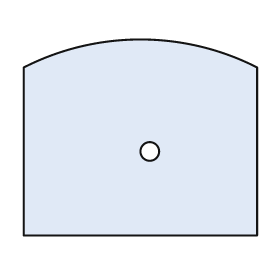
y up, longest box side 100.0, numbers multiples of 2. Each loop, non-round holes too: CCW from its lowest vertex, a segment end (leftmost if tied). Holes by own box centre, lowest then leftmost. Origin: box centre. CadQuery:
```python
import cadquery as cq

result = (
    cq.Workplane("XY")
    .moveTo(-50.0, -42.0)
    .lineTo(50.0, -42.0)
    .lineTo(50.0, 30.0)
    .threePointArc((0.0, 42.0), (-50.0, 30.0))
    .close()
    .moveTo(4.0, -6.0)
    .circle(4.0)
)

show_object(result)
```